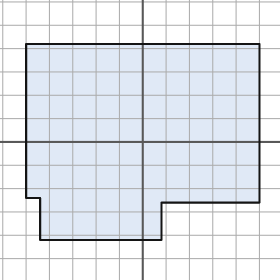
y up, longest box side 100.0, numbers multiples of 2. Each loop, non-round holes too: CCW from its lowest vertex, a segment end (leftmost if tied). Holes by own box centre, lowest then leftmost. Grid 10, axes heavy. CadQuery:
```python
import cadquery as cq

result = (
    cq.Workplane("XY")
    .moveTo(-44.0, -42.0)
    .lineTo(8.0, -42.0)
    .lineTo(8.0, -26.0)
    .lineTo(50.0, -26.0)
    .lineTo(50.0, 42.0)
    .lineTo(-50.0, 42.0)
    .lineTo(-50.0, -24.0)
    .lineTo(-44.0, -24.0)
    .close()
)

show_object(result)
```